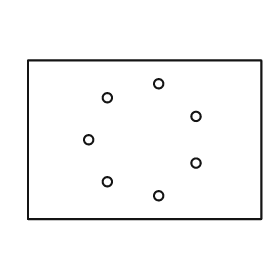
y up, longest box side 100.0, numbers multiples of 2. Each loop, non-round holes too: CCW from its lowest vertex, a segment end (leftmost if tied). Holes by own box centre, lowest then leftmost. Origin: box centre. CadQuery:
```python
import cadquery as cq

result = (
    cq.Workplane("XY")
    .moveTo(-50.0, -34.0)
    .lineTo(50.0, -34.0)
    .lineTo(50.0, 34.0)
    .lineTo(-50.0, 34.0)
    .close()
    .moveTo(6.0, -24.0)
    .circle(2.0)
    .moveTo(-16.0, -18.0)
    .circle(2.0)
    .moveTo(22.0, -10.0)
    .circle(2.0)
    .moveTo(-24.0, 0.0)
    .circle(2.0)
    .moveTo(22.0, 10.0)
    .circle(2.0)
    .moveTo(-16.0, 18.0)
    .circle(2.0)
    .moveTo(6.0, 24.0)
    .circle(2.0)
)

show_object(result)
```